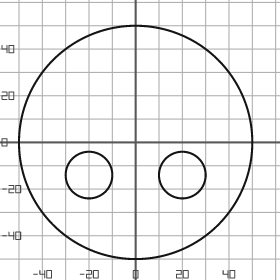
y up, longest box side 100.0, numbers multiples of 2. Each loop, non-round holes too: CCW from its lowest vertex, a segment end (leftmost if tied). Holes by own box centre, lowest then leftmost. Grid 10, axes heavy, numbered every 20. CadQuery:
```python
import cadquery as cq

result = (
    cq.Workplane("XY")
    .moveTo(0.0, 0.0)
    .circle(50.0)
    .moveTo(-20.0, -14.0)
    .circle(10.0)
    .moveTo(20.0, -14.0)
    .circle(10.0)
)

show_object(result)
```